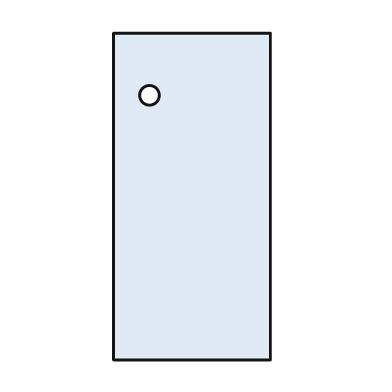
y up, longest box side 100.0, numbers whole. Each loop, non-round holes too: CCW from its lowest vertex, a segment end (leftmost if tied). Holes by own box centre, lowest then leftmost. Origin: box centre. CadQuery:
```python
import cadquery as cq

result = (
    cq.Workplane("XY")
    .moveTo(-24.0, -50.0)
    .lineTo(24.0, -50.0)
    .lineTo(24.0, 50.0)
    .lineTo(-24.0, 50.0)
    .close()
    .moveTo(-13.0, 31.0)
    .circle(3.0)
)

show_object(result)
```